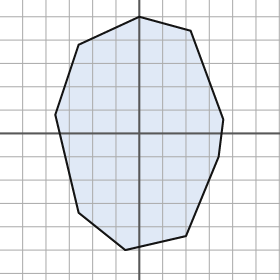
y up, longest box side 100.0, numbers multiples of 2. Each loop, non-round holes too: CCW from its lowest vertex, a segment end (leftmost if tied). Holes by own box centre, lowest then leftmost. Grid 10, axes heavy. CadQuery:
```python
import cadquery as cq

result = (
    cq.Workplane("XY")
    .moveTo(-6.0, -50.0)
    .lineTo(20.0, -44.0)
    .lineTo(34.0, -10.0)
    .lineTo(36.0, 6.0)
    .lineTo(22.0, 44.0)
    .lineTo(0.0, 50.0)
    .lineTo(-26.0, 38.0)
    .lineTo(-36.0, 8.0)
    .lineTo(-26.0, -34.0)
    .close()
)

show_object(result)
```